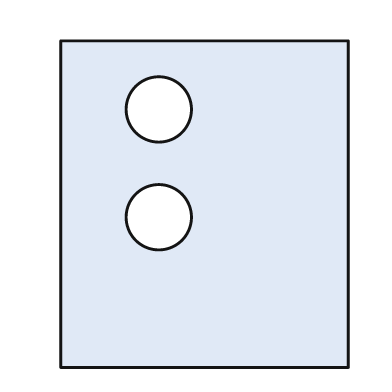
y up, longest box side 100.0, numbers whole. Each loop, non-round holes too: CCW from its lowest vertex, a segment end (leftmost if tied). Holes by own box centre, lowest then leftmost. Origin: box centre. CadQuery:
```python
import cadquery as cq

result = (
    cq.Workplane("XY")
    .moveTo(-44.0, -50.0)
    .lineTo(44.0, -50.0)
    .lineTo(44.0, 50.0)
    .lineTo(-44.0, 50.0)
    .close()
    .moveTo(-14.0, -4.0)
    .circle(10.0)
    .moveTo(-14.0, 29.0)
    .circle(10.0)
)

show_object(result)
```